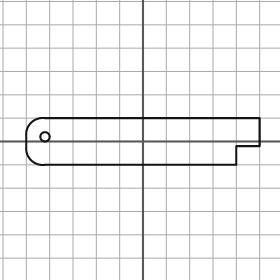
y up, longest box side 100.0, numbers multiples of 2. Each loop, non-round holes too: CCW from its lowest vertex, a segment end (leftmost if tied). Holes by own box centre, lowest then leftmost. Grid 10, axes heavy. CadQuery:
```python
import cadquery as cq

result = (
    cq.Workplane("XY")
    .moveTo(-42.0, -10.0)
    .lineTo(40.0, -10.0)
    .lineTo(40.0, -2.0)
    .lineTo(50.0, -2.0)
    .lineTo(50.0, 10.0)
    .lineTo(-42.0, 10.0)
    .threePointArc((-48.0, 8.0), (-50.0, 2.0))
    .lineTo(-50.0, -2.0)
    .threePointArc((-48.0, -8.0), (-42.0, -10.0))
    .close()
    .moveTo(-42.0, 2.0)
    .circle(2.0)
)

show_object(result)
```